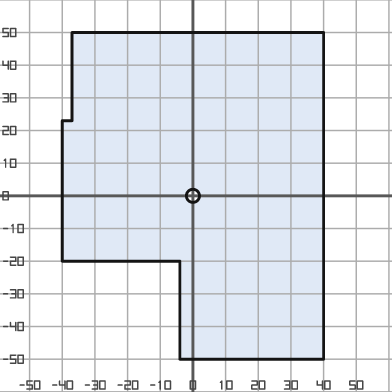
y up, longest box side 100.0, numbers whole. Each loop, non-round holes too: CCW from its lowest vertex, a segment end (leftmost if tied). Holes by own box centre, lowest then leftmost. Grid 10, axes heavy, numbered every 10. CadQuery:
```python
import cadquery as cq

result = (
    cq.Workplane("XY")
    .moveTo(-4.0, -50.0)
    .lineTo(40.0, -50.0)
    .lineTo(40.0, 50.0)
    .lineTo(-37.0, 50.0)
    .lineTo(-37.0, 23.0)
    .lineTo(-40.0, 23.0)
    .lineTo(-40.0, -20.0)
    .lineTo(-4.0, -20.0)
    .close()
    .moveTo(0.0, 0.0)
    .circle(2.0)
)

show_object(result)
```